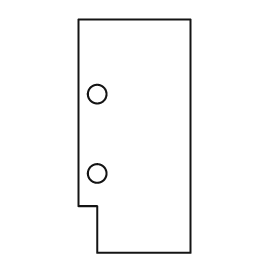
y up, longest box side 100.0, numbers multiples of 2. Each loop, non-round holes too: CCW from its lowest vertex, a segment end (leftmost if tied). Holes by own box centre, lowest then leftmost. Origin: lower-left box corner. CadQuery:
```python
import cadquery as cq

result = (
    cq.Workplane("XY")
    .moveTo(8.0, 0.0)
    .lineTo(48.0, 0.0)
    .lineTo(48.0, 100.0)
    .lineTo(0.0, 100.0)
    .lineTo(0.0, 20.0)
    .lineTo(8.0, 20.0)
    .close()
    .moveTo(8.0, 34.0)
    .circle(4.0)
    .moveTo(8.0, 68.0)
    .circle(4.0)
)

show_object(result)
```